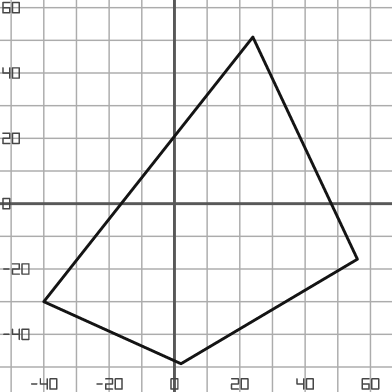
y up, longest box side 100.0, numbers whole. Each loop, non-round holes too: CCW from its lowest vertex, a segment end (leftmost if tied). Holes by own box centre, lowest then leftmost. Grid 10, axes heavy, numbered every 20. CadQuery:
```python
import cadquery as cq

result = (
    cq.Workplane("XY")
    .moveTo(2.0, -49.0)
    .lineTo(56.0, -17.0)
    .lineTo(24.0, 51.0)
    .lineTo(-40.0, -30.0)
    .close()
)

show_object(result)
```